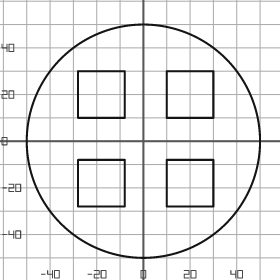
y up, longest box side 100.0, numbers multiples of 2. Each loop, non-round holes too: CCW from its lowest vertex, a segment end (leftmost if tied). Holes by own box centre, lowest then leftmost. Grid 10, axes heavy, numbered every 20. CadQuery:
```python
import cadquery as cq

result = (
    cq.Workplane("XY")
    .moveTo(0.0, 0.0)
    .circle(50.0)
    .moveTo(-28.0, -28.0)
    .lineTo(-8.0, -28.0)
    .lineTo(-8.0, -8.0)
    .lineTo(-28.0, -8.0)
    .close()
    .moveTo(10.0, -28.0)
    .lineTo(30.0, -28.0)
    .lineTo(30.0, -8.0)
    .lineTo(10.0, -8.0)
    .close()
    .moveTo(-28.0, 10.0)
    .lineTo(-8.0, 10.0)
    .lineTo(-8.0, 30.0)
    .lineTo(-28.0, 30.0)
    .close()
    .moveTo(10.0, 10.0)
    .lineTo(30.0, 10.0)
    .lineTo(30.0, 30.0)
    .lineTo(10.0, 30.0)
    .close()
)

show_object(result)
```